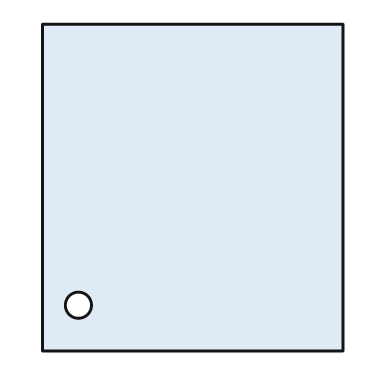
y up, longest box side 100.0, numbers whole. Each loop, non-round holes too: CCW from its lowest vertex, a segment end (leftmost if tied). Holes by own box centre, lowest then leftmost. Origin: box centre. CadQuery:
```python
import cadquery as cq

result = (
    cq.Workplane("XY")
    .moveTo(-46.0, -50.0)
    .lineTo(46.0, -50.0)
    .lineTo(46.0, 50.0)
    .lineTo(-46.0, 50.0)
    .close()
    .moveTo(-35.0, -36.0)
    .circle(4.0)
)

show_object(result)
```